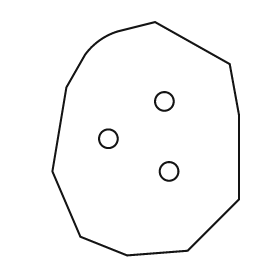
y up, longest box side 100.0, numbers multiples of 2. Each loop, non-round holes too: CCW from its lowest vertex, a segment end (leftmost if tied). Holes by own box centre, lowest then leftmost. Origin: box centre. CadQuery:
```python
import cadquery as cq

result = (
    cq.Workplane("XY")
    .moveTo(-8.0, -50.0)
    .lineTo(18.0, -48.0)
    .lineTo(40.0, -26.0)
    .lineTo(40.0, 10.0)
    .lineTo(36.0, 32.0)
    .lineTo(4.0, 50.0)
    .lineTo(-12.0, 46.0)
    .threePointArc((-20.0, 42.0), (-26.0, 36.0))
    .lineTo(-34.0, 22.0)
    .lineTo(-40.0, -14.0)
    .lineTo(-28.0, -42.0)
    .close()
    .moveTo(10.0, -14.0)
    .circle(4.0)
    .moveTo(-16.0, 0.0)
    .circle(4.0)
    .moveTo(8.0, 16.0)
    .circle(4.0)
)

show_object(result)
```